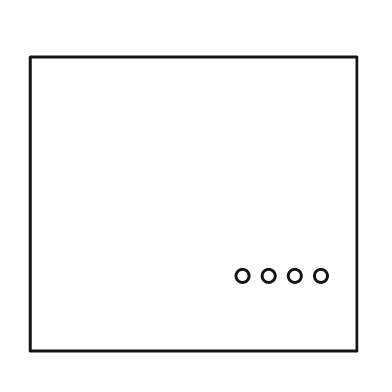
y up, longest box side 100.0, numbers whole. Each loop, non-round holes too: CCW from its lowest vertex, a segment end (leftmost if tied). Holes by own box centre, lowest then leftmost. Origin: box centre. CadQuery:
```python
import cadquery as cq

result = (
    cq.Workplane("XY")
    .moveTo(-50.0, -45.0)
    .lineTo(50.0, -45.0)
    .lineTo(50.0, 45.0)
    .lineTo(-50.0, 45.0)
    .close()
    .moveTo(15.0, -22.0)
    .circle(2.0)
    .moveTo(23.0, -22.0)
    .circle(2.0)
    .moveTo(31.0, -22.0)
    .circle(2.0)
    .moveTo(39.0, -22.0)
    .circle(2.0)
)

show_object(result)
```